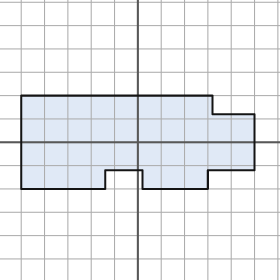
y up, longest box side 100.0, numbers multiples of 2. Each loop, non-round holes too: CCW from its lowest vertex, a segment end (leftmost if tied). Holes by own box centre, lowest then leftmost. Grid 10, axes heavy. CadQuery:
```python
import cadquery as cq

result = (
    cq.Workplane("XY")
    .moveTo(-50.0, -20.0)
    .lineTo(-14.0, -20.0)
    .lineTo(-14.0, -12.0)
    .lineTo(2.0, -12.0)
    .lineTo(2.0, -20.0)
    .lineTo(30.0, -20.0)
    .lineTo(30.0, -12.0)
    .lineTo(50.0, -12.0)
    .lineTo(50.0, 12.0)
    .lineTo(32.0, 12.0)
    .lineTo(32.0, 20.0)
    .lineTo(-50.0, 20.0)
    .close()
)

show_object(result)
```